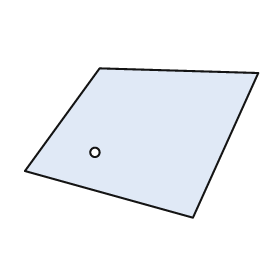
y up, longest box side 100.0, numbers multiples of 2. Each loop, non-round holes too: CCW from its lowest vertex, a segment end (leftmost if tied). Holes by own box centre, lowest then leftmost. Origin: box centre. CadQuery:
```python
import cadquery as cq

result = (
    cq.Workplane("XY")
    .moveTo(22.0, -32.0)
    .lineTo(50.0, 30.0)
    .lineTo(-18.0, 32.0)
    .lineTo(-50.0, -12.0)
    .close()
    .moveTo(-20.0, -4.0)
    .circle(2.0)
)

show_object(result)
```